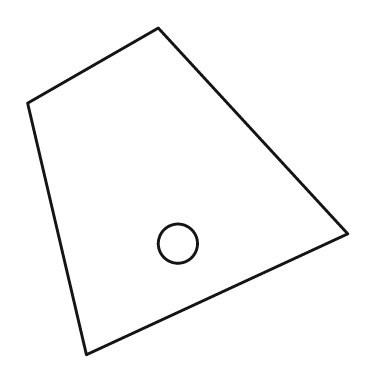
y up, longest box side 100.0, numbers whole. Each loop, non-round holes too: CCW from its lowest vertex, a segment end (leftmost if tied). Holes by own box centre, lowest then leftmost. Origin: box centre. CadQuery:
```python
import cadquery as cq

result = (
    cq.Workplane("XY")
    .moveTo(-31.0, -50.0)
    .lineTo(49.0, -13.0)
    .lineTo(-9.0, 50.0)
    .lineTo(-49.0, 27.0)
    .close()
    .moveTo(-3.0, -16.0)
    .circle(6.0)
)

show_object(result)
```